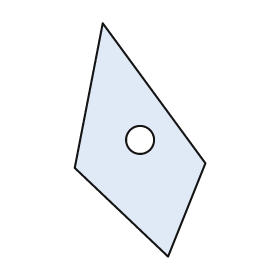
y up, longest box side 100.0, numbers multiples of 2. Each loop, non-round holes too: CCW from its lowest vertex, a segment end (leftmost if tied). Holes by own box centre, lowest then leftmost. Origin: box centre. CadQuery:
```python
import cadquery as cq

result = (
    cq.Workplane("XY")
    .moveTo(12.0, -50.0)
    .lineTo(28.0, -10.0)
    .lineTo(-16.0, 50.0)
    .lineTo(-28.0, -12.0)
    .close()
    .moveTo(0.0, 0.0)
    .circle(6.0)
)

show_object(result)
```